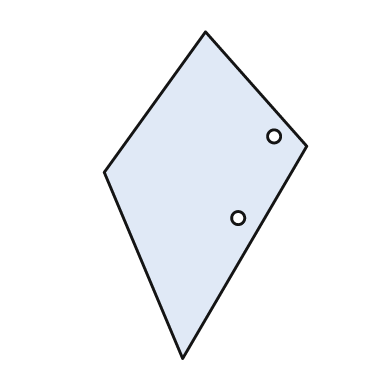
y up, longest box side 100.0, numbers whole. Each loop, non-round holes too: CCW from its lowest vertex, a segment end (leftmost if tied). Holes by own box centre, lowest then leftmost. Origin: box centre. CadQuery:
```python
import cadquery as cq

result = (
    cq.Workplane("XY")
    .moveTo(-7.0, -50.0)
    .lineTo(31.0, 15.0)
    .lineTo(0.0, 50.0)
    .lineTo(-31.0, 7.0)
    .close()
    .moveTo(10.0, -7.0)
    .circle(2.0)
    .moveTo(21.0, 18.0)
    .circle(2.0)
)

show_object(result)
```